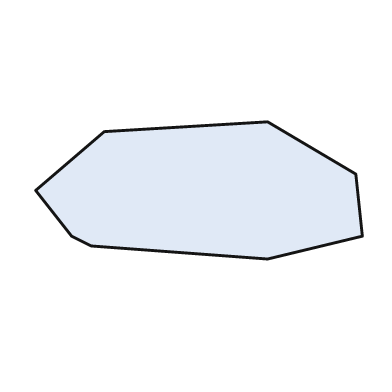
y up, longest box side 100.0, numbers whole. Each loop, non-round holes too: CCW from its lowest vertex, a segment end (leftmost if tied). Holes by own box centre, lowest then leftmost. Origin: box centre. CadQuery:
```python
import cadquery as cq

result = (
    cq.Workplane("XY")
    .moveTo(21.0, -21.0)
    .lineTo(50.0, -14.0)
    .lineTo(48.0, 5.0)
    .lineTo(21.0, 21.0)
    .lineTo(-29.0, 18.0)
    .lineTo(-50.0, 0.0)
    .lineTo(-39.0, -14.0)
    .lineTo(-33.0, -17.0)
    .close()
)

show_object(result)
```